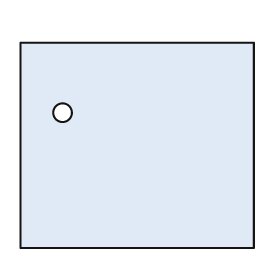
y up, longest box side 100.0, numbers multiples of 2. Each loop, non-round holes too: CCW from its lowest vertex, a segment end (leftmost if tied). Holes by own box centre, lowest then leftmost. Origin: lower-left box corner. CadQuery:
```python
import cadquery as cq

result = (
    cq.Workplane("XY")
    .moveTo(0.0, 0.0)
    .lineTo(100.0, 0.0)
    .lineTo(100.0, 88.0)
    .lineTo(0.0, 88.0)
    .close()
    .moveTo(18.0, 58.0)
    .circle(4.0)
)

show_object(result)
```